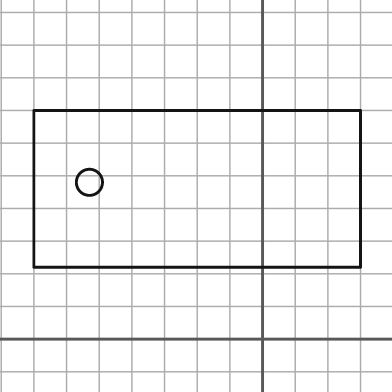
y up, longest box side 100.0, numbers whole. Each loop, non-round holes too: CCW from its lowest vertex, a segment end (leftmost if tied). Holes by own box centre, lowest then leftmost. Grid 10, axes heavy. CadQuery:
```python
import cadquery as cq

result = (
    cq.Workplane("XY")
    .moveTo(-70.0, 22.0)
    .lineTo(30.0, 22.0)
    .lineTo(30.0, 70.0)
    .lineTo(-70.0, 70.0)
    .close()
    .moveTo(-53.0, 48.0)
    .circle(4.0)
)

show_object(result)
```